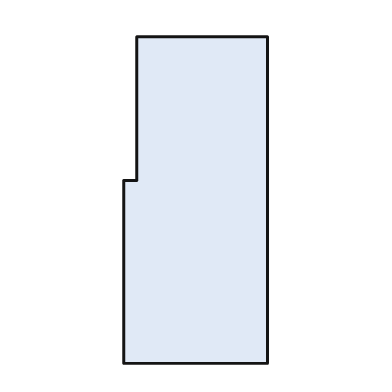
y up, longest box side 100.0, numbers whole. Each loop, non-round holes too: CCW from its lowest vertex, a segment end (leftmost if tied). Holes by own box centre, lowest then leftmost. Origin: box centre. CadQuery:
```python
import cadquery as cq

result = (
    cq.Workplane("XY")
    .moveTo(-22.0, -50.0)
    .lineTo(22.0, -50.0)
    .lineTo(22.0, 50.0)
    .lineTo(-18.0, 50.0)
    .lineTo(-18.0, 6.0)
    .lineTo(-22.0, 6.0)
    .close()
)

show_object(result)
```